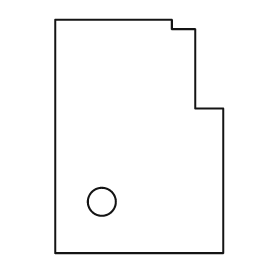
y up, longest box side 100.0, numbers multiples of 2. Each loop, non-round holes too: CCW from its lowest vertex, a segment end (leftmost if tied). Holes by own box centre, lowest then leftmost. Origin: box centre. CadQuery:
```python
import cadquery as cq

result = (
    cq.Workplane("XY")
    .moveTo(-36.0, -50.0)
    .lineTo(36.0, -50.0)
    .lineTo(36.0, 12.0)
    .lineTo(24.0, 12.0)
    .lineTo(24.0, 46.0)
    .lineTo(14.0, 46.0)
    .lineTo(14.0, 50.0)
    .lineTo(-36.0, 50.0)
    .close()
    .moveTo(-16.0, -28.0)
    .circle(6.0)
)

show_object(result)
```